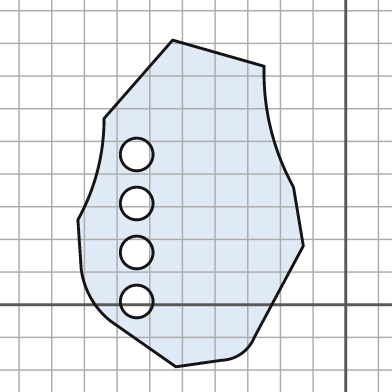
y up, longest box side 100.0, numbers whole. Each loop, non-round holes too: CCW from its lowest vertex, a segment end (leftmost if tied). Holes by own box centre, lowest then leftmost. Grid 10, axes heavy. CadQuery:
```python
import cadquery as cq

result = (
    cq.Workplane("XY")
    .moveTo(-52.0, -19.0)
    .lineTo(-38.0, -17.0)
    .threePointArc((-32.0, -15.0), (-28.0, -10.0))
    .lineTo(-13.0, 18.0)
    .lineTo(-16.0, 36.0)
    .threePointArc((-23.0, 54.0), (-25.0, 73.0))
    .lineTo(-53.0, 81.0)
    .lineTo(-74.0, 57.0)
    .threePointArc((-76.0, 41.0), (-82.0, 26.0))
    .lineTo(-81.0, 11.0)
    .threePointArc((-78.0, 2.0), (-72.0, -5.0))
    .close()
    .moveTo(-64.0, 1.0)
    .circle(5.0)
    .moveTo(-64.0, 16.0)
    .circle(5.0)
    .moveTo(-64.0, 31.0)
    .circle(5.0)
    .moveTo(-64.0, 46.0)
    .circle(5.0)
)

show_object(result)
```